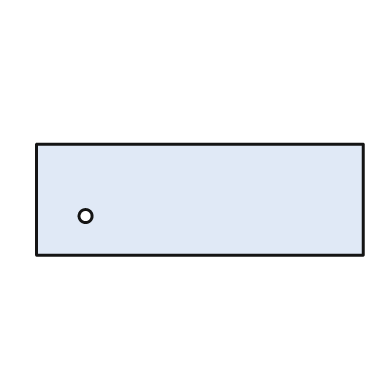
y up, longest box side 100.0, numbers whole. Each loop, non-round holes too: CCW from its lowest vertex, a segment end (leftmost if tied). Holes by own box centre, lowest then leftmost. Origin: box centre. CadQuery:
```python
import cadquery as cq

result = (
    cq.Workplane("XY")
    .moveTo(-50.0, -17.0)
    .lineTo(50.0, -17.0)
    .lineTo(50.0, 17.0)
    .lineTo(-50.0, 17.0)
    .close()
    .moveTo(-35.0, -5.0)
    .circle(2.0)
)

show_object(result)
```